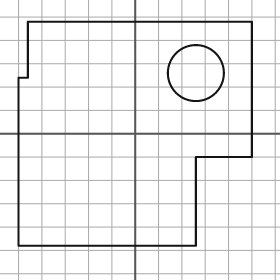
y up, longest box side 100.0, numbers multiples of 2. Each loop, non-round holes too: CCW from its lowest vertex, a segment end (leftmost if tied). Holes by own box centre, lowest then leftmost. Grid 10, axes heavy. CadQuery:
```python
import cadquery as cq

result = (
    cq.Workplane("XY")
    .moveTo(-50.0, -48.0)
    .lineTo(26.0, -48.0)
    .lineTo(26.0, -10.0)
    .lineTo(50.0, -10.0)
    .lineTo(50.0, 48.0)
    .lineTo(-46.0, 48.0)
    .lineTo(-46.0, 24.0)
    .lineTo(-50.0, 24.0)
    .close()
    .moveTo(26.0, 26.0)
    .circle(12.0)
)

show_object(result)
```